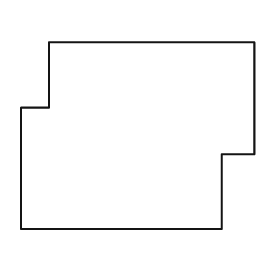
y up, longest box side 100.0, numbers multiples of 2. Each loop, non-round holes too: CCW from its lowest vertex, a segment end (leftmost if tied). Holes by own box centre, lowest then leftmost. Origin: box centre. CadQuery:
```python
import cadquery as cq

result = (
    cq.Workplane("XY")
    .moveTo(-50.0, -40.0)
    .lineTo(36.0, -40.0)
    .lineTo(36.0, -8.0)
    .lineTo(50.0, -8.0)
    .lineTo(50.0, 40.0)
    .lineTo(-38.0, 40.0)
    .lineTo(-38.0, 12.0)
    .lineTo(-50.0, 12.0)
    .close()
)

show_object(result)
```